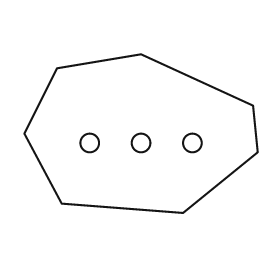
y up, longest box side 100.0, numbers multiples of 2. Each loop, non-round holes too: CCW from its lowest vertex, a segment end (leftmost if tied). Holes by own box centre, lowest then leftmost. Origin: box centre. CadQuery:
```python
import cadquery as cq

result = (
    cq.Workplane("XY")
    .moveTo(18.0, -34.0)
    .lineTo(50.0, -8.0)
    .lineTo(48.0, 12.0)
    .lineTo(0.0, 34.0)
    .lineTo(-36.0, 28.0)
    .lineTo(-50.0, 0.0)
    .lineTo(-34.0, -30.0)
    .close()
    .moveTo(-22.0, -4.0)
    .circle(4.0)
    .moveTo(0.0, -4.0)
    .circle(4.0)
    .moveTo(22.0, -4.0)
    .circle(4.0)
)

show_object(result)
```